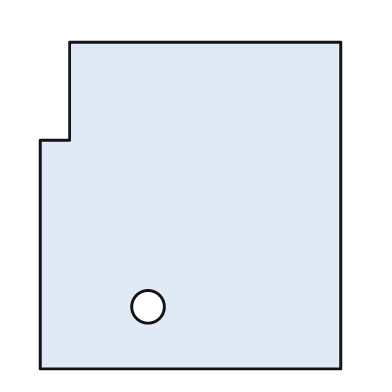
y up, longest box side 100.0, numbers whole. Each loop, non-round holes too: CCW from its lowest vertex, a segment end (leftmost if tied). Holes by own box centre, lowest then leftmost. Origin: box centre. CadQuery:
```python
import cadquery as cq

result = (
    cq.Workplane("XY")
    .moveTo(-46.0, -50.0)
    .lineTo(46.0, -50.0)
    .lineTo(46.0, 50.0)
    .lineTo(-37.0, 50.0)
    .lineTo(-37.0, 20.0)
    .lineTo(-46.0, 20.0)
    .close()
    .moveTo(-13.0, -31.0)
    .circle(5.0)
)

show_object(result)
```